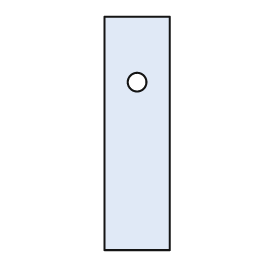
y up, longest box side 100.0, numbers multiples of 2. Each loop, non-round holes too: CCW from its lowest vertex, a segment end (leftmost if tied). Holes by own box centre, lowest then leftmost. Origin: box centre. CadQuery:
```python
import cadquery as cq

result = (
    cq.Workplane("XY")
    .moveTo(-14.0, -50.0)
    .lineTo(14.0, -50.0)
    .lineTo(14.0, 50.0)
    .lineTo(-14.0, 50.0)
    .close()
    .moveTo(0.0, 22.0)
    .circle(4.0)
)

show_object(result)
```